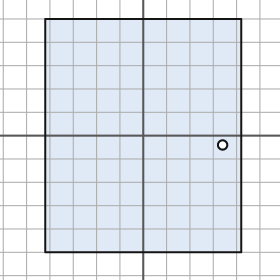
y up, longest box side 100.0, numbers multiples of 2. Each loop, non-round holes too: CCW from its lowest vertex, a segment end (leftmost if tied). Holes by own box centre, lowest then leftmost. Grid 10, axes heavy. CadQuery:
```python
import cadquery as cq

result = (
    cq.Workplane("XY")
    .moveTo(-42.0, -50.0)
    .lineTo(42.0, -50.0)
    .lineTo(42.0, 50.0)
    .lineTo(-42.0, 50.0)
    .close()
    .moveTo(34.0, -4.0)
    .circle(2.0)
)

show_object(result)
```